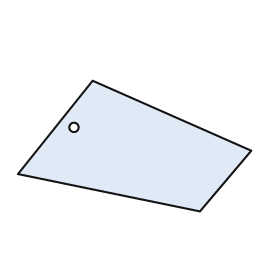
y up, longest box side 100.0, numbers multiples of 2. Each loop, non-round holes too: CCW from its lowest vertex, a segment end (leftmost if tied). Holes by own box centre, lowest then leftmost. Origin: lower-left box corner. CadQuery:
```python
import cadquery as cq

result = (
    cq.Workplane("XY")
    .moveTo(78.0, 0.0)
    .lineTo(100.0, 26.0)
    .lineTo(32.0, 56.0)
    .lineTo(0.0, 16.0)
    .close()
    .moveTo(24.0, 36.0)
    .circle(2.0)
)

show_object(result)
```